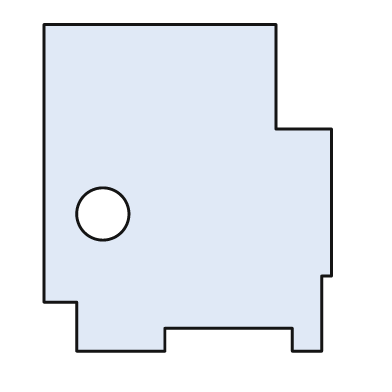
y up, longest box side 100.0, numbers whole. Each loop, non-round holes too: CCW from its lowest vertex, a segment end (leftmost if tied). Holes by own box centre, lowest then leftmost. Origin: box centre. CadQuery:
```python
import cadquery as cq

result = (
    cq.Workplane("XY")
    .moveTo(-34.0, -50.0)
    .lineTo(-7.0, -50.0)
    .lineTo(-7.0, -43.0)
    .lineTo(32.0, -43.0)
    .lineTo(32.0, -50.0)
    .lineTo(41.0, -50.0)
    .lineTo(41.0, -27.0)
    .lineTo(44.0, -27.0)
    .lineTo(44.0, 18.0)
    .lineTo(27.0, 18.0)
    .lineTo(27.0, 50.0)
    .lineTo(-44.0, 50.0)
    .lineTo(-44.0, -35.0)
    .lineTo(-34.0, -35.0)
    .close()
    .moveTo(-26.0, -8.0)
    .circle(8.0)
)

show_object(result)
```